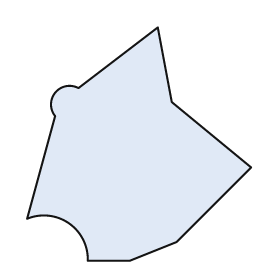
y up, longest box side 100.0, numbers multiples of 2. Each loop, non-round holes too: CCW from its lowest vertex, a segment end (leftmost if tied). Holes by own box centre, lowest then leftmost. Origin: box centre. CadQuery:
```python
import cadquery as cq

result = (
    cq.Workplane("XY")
    .moveTo(-22.0, -50.0)
    .lineTo(-4.0, -50.0)
    .lineTo(16.0, -42.0)
    .lineTo(48.0, -10.0)
    .lineTo(14.0, 18.0)
    .lineTo(8.0, 50.0)
    .lineTo(-26.0, 24.0)
    .threePointArc((-36.0, 22.0), (-36.0, 12.0))
    .lineTo(-48.0, -32.0)
    .threePointArc((-30.0, -34.0), (-22.0, -50.0))
    .close()
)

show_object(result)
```